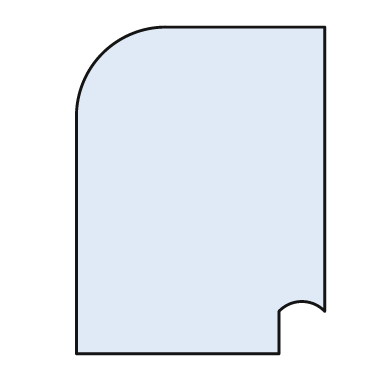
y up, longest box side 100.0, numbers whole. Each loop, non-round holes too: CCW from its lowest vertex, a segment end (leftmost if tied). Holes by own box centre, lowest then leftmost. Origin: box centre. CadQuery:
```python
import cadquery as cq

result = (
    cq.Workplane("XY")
    .moveTo(-38.0, -50.0)
    .lineTo(24.0, -50.0)
    .lineTo(24.0, -37.0)
    .threePointArc((31.0, -34.0), (38.0, -37.0))
    .lineTo(38.0, 50.0)
    .lineTo(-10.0, 50.0)
    .threePointArc((-30.0, 42.0), (-38.0, 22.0))
    .close()
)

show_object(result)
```